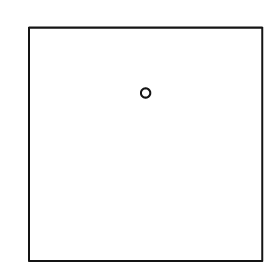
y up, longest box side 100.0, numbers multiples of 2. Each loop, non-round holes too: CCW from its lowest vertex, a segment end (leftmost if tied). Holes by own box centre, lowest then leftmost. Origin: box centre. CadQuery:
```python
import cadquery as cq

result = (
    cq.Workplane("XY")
    .moveTo(-50.0, -50.0)
    .lineTo(50.0, -50.0)
    .lineTo(50.0, 50.0)
    .lineTo(-50.0, 50.0)
    .close()
    .moveTo(0.0, 22.0)
    .circle(2.0)
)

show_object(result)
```